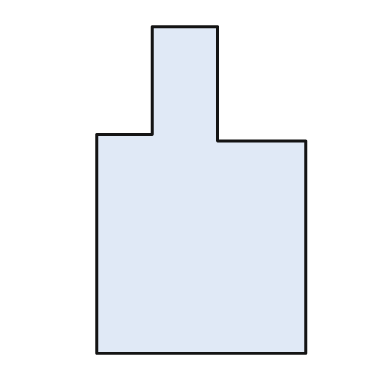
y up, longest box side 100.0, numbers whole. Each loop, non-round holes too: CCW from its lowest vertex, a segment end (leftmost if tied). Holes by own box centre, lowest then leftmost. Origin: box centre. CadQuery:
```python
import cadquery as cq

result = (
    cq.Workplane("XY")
    .moveTo(-32.0, -50.0)
    .lineTo(32.0, -50.0)
    .lineTo(32.0, 15.0)
    .lineTo(5.0, 15.0)
    .lineTo(5.0, 50.0)
    .lineTo(-15.0, 50.0)
    .lineTo(-15.0, 17.0)
    .lineTo(-32.0, 17.0)
    .close()
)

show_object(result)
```